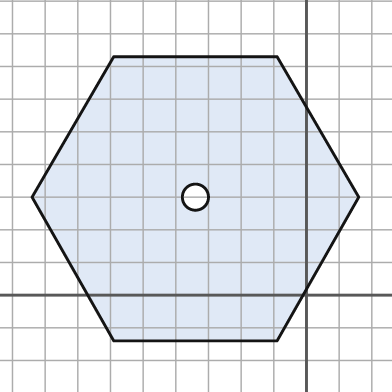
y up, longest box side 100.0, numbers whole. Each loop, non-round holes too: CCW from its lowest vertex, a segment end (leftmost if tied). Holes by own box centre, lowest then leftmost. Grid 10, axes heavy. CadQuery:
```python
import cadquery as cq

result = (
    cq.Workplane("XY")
    .moveTo(-59.0, -14.0)
    .lineTo(-9.0, -14.0)
    .lineTo(16.0, 30.0)
    .lineTo(-9.0, 73.0)
    .lineTo(-59.0, 73.0)
    .lineTo(-84.0, 30.0)
    .close()
    .moveTo(-34.0, 30.0)
    .circle(4.0)
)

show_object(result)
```